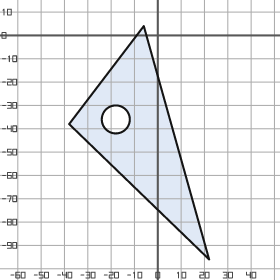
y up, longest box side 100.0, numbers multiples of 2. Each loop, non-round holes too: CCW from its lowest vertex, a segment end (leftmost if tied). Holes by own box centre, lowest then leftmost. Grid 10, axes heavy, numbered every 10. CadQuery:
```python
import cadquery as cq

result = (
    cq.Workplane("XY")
    .moveTo(22.0, -96.0)
    .lineTo(-6.0, 4.0)
    .lineTo(-38.0, -38.0)
    .close()
    .moveTo(-18.0, -36.0)
    .circle(6.0)
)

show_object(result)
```